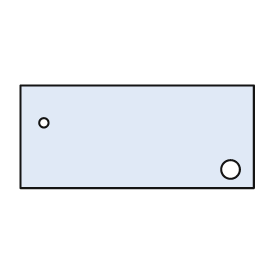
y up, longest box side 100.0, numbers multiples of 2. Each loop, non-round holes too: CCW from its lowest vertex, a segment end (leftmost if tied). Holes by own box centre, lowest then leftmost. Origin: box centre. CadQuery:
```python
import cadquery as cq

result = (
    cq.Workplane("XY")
    .moveTo(-50.0, -22.0)
    .lineTo(50.0, -22.0)
    .lineTo(50.0, 22.0)
    .lineTo(-50.0, 22.0)
    .close()
    .moveTo(40.0, -14.0)
    .circle(4.0)
    .moveTo(-40.0, 6.0)
    .circle(2.0)
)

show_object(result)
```